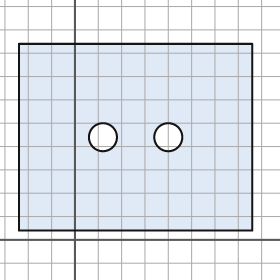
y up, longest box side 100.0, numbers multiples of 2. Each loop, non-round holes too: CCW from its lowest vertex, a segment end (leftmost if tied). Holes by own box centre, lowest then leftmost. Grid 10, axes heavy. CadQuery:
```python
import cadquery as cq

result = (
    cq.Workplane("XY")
    .moveTo(-24.0, 4.0)
    .lineTo(76.0, 4.0)
    .lineTo(76.0, 84.0)
    .lineTo(-24.0, 84.0)
    .close()
    .moveTo(12.0, 44.0)
    .circle(6.0)
    .moveTo(40.0, 44.0)
    .circle(6.0)
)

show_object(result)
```